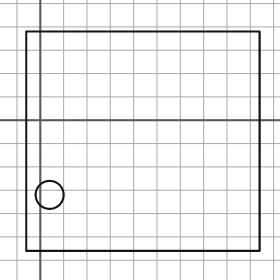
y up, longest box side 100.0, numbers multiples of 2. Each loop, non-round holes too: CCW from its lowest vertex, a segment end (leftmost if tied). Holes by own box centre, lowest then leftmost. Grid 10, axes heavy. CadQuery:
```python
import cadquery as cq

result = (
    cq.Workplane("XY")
    .moveTo(-6.0, -56.0)
    .lineTo(94.0, -56.0)
    .lineTo(94.0, 38.0)
    .lineTo(-6.0, 38.0)
    .close()
    .moveTo(4.0, -32.0)
    .circle(6.0)
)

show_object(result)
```